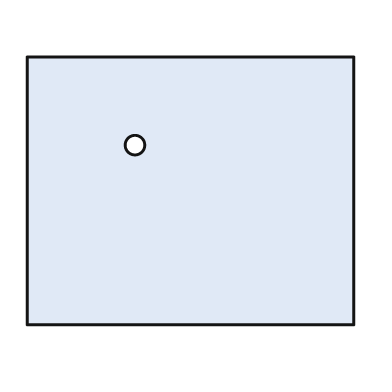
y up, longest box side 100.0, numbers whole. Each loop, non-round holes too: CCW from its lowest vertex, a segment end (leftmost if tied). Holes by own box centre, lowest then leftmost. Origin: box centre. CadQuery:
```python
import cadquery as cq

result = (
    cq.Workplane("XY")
    .moveTo(-50.0, -41.0)
    .lineTo(50.0, -41.0)
    .lineTo(50.0, 41.0)
    .lineTo(-50.0, 41.0)
    .close()
    .moveTo(-17.0, 14.0)
    .circle(3.0)
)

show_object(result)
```